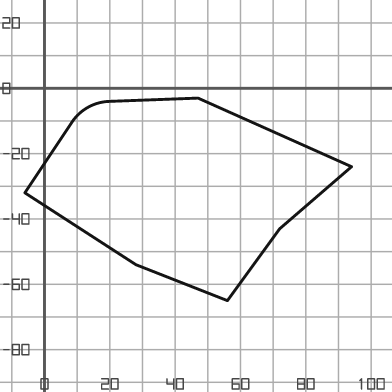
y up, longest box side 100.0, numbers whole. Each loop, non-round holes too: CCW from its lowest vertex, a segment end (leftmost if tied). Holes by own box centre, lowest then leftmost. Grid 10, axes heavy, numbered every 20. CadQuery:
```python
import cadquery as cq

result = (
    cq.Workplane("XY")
    .moveTo(56.0, -65.0)
    .lineTo(72.0, -43.0)
    .lineTo(94.0, -24.0)
    .lineTo(47.0, -3.0)
    .lineTo(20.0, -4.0)
    .threePointArc((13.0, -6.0), (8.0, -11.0))
    .lineTo(-6.0, -32.0)
    .lineTo(28.0, -54.0)
    .close()
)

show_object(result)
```